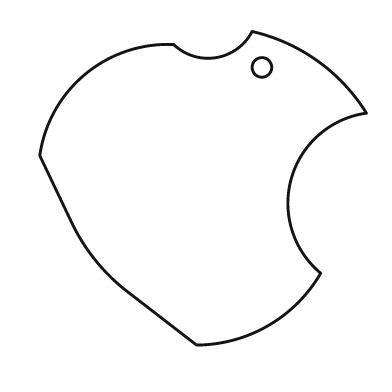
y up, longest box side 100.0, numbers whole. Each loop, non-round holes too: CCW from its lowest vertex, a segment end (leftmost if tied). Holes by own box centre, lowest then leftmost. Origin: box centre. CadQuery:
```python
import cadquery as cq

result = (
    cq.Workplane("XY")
    .moveTo(-2.0, -48.0)
    .threePointArc((20.0, -42.0), (36.0, -26.0))
    .threePointArc((27.0, 3.0), (50.0, 23.0))
    .threePointArc((35.0, 39.0), (15.0, 48.0))
    .threePointArc((4.0, 40.0), (-9.0, 44.0))
    .threePointArc((-36.0, 35.0), (-50.0, 10.0))
    .lineTo(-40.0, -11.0)
    .threePointArc((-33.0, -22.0), (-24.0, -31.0))
    .close()
    .moveTo(18.0, 37.0)
    .circle(3.0)
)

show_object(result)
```